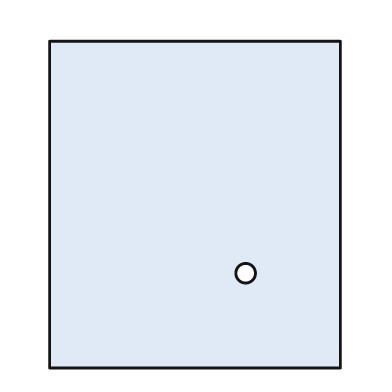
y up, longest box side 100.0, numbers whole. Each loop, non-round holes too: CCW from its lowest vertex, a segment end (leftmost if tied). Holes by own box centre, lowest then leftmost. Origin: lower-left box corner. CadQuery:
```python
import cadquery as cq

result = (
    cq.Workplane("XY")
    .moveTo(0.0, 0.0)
    .lineTo(89.0, 0.0)
    .lineTo(89.0, 100.0)
    .lineTo(0.0, 100.0)
    .close()
    .moveTo(60.0, 29.0)
    .circle(3.0)
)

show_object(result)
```